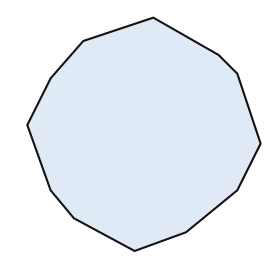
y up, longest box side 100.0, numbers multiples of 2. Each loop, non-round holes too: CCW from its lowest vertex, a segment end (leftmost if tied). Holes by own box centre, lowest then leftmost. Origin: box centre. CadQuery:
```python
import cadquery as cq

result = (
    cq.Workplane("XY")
    .moveTo(-4.0, -50.0)
    .lineTo(18.0, -42.0)
    .lineTo(40.0, -24.0)
    .lineTo(50.0, -4.0)
    .lineTo(40.0, 26.0)
    .lineTo(32.0, 34.0)
    .lineTo(4.0, 50.0)
    .lineTo(-26.0, 40.0)
    .lineTo(-40.0, 24.0)
    .lineTo(-50.0, 4.0)
    .lineTo(-40.0, -24.0)
    .lineTo(-30.0, -36.0)
    .close()
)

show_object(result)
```